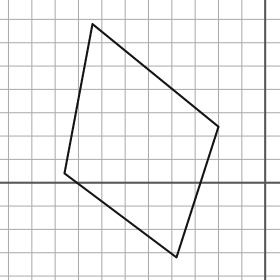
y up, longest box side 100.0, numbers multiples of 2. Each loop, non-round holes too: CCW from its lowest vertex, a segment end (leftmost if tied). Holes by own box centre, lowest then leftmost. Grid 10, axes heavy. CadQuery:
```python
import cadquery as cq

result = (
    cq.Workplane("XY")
    .moveTo(-38.0, -32.0)
    .lineTo(-20.0, 24.0)
    .lineTo(-74.0, 68.0)
    .lineTo(-86.0, 4.0)
    .close()
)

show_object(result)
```